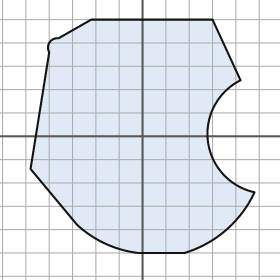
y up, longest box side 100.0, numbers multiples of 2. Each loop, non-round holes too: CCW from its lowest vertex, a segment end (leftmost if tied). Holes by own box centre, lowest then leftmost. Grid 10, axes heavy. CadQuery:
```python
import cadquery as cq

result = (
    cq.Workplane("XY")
    .moveTo(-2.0, -50.0)
    .lineTo(18.0, -50.0)
    .threePointArc((36.0, -40.0), (48.0, -24.0))
    .threePointArc((28.0, -2.0), (42.0, 24.0))
    .lineTo(30.0, 50.0)
    .lineTo(-22.0, 50.0)
    .lineTo(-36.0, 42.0)
    .threePointArc((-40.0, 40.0), (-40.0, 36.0))
    .lineTo(-48.0, -14.0)
    .lineTo(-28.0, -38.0)
    .threePointArc((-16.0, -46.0), (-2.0, -50.0))
    .close()
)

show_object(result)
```